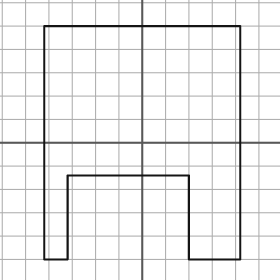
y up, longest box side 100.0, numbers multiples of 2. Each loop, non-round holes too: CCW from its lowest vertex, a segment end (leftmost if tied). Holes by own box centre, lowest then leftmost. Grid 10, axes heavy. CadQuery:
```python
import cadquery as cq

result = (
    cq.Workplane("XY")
    .moveTo(-42.0, -50.0)
    .lineTo(-32.0, -50.0)
    .lineTo(-32.0, -14.0)
    .lineTo(20.0, -14.0)
    .lineTo(20.0, -50.0)
    .lineTo(42.0, -50.0)
    .lineTo(42.0, 50.0)
    .lineTo(-42.0, 50.0)
    .close()
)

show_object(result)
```